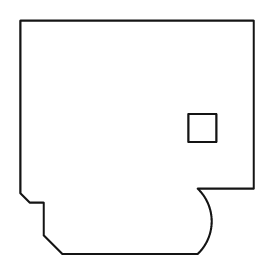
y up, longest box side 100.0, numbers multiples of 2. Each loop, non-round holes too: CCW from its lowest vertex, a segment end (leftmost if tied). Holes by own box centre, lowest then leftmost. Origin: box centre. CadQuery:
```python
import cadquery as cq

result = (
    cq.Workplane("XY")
    .moveTo(-32.0, -50.0)
    .lineTo(26.0, -50.0)
    .threePointArc((32.0, -36.0), (26.0, -22.0))
    .lineTo(50.0, -22.0)
    .lineTo(50.0, 50.0)
    .lineTo(-50.0, 50.0)
    .lineTo(-50.0, -24.0)
    .lineTo(-46.0, -28.0)
    .lineTo(-40.0, -28.0)
    .lineTo(-40.0, -42.0)
    .close()
    .moveTo(22.0, -2.0)
    .lineTo(34.0, -2.0)
    .lineTo(34.0, 10.0)
    .lineTo(22.0, 10.0)
    .close()
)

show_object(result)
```